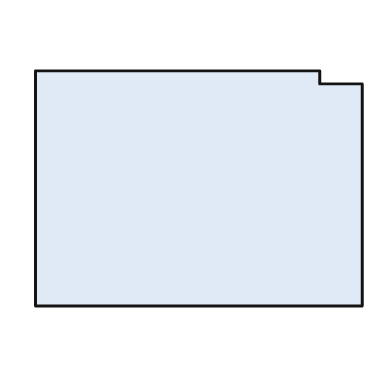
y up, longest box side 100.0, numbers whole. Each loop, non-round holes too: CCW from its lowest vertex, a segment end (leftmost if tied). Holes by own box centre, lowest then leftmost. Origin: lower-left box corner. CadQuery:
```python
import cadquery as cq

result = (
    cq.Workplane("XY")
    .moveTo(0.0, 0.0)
    .lineTo(100.0, 0.0)
    .lineTo(100.0, 68.0)
    .lineTo(87.0, 68.0)
    .lineTo(87.0, 72.0)
    .lineTo(0.0, 72.0)
    .close()
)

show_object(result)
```